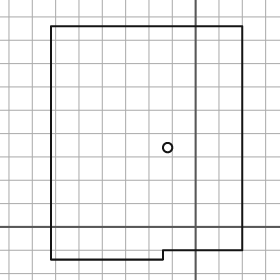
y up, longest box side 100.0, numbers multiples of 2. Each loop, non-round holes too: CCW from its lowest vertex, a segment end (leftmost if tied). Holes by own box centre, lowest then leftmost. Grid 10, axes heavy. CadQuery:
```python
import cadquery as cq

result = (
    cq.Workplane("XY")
    .moveTo(-62.0, -14.0)
    .lineTo(-14.0, -14.0)
    .lineTo(-14.0, -10.0)
    .lineTo(20.0, -10.0)
    .lineTo(20.0, 86.0)
    .lineTo(-62.0, 86.0)
    .close()
    .moveTo(-12.0, 34.0)
    .circle(2.0)
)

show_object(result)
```